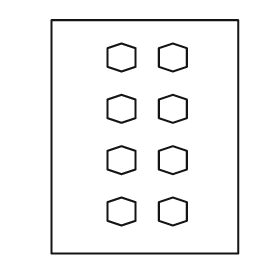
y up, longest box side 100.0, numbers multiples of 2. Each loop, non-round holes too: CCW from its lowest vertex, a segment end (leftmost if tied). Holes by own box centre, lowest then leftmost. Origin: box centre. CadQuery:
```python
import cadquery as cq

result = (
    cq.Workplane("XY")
    .moveTo(-40.0, -50.0)
    .lineTo(40.0, -50.0)
    .lineTo(40.0, 50.0)
    .lineTo(-40.0, 50.0)
    .close()
    .moveTo(-10.0, -38.0)
    .lineTo(-4.0, -36.0)
    .lineTo(-4.0, -28.0)
    .lineTo(-10.0, -26.0)
    .lineTo(-16.0, -28.0)
    .lineTo(-16.0, -36.0)
    .close()
    .moveTo(12.0, -38.0)
    .lineTo(18.0, -36.0)
    .lineTo(18.0, -28.0)
    .lineTo(12.0, -26.0)
    .lineTo(6.0, -28.0)
    .lineTo(6.0, -36.0)
    .close()
    .moveTo(-10.0, -16.0)
    .lineTo(-4.0, -14.0)
    .lineTo(-4.0, -6.0)
    .lineTo(-10.0, -4.0)
    .lineTo(-16.0, -6.0)
    .lineTo(-16.0, -14.0)
    .close()
    .moveTo(12.0, -16.0)
    .lineTo(18.0, -14.0)
    .lineTo(18.0, -6.0)
    .lineTo(12.0, -4.0)
    .lineTo(6.0, -6.0)
    .lineTo(6.0, -14.0)
    .close()
    .moveTo(-10.0, 6.0)
    .lineTo(-4.0, 8.0)
    .lineTo(-4.0, 16.0)
    .lineTo(-10.0, 18.0)
    .lineTo(-16.0, 16.0)
    .lineTo(-16.0, 8.0)
    .close()
    .moveTo(12.0, 6.0)
    .lineTo(18.0, 8.0)
    .lineTo(18.0, 16.0)
    .lineTo(12.0, 18.0)
    .lineTo(6.0, 16.0)
    .lineTo(6.0, 8.0)
    .close()
    .moveTo(-10.0, 28.0)
    .lineTo(-4.0, 30.0)
    .lineTo(-4.0, 38.0)
    .lineTo(-10.0, 40.0)
    .lineTo(-16.0, 38.0)
    .lineTo(-16.0, 30.0)
    .close()
    .moveTo(12.0, 28.0)
    .lineTo(18.0, 30.0)
    .lineTo(18.0, 38.0)
    .lineTo(12.0, 40.0)
    .lineTo(6.0, 38.0)
    .lineTo(6.0, 30.0)
    .close()
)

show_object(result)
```